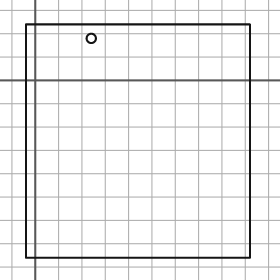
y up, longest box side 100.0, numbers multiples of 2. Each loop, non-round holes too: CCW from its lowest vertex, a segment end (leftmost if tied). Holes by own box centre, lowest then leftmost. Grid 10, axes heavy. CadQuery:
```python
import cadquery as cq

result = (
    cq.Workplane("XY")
    .moveTo(-4.0, -76.0)
    .lineTo(92.0, -76.0)
    .lineTo(92.0, 24.0)
    .lineTo(-4.0, 24.0)
    .close()
    .moveTo(24.0, 18.0)
    .circle(2.0)
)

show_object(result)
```